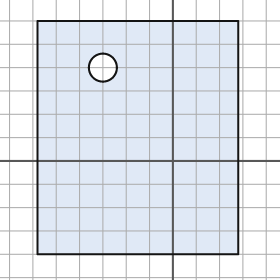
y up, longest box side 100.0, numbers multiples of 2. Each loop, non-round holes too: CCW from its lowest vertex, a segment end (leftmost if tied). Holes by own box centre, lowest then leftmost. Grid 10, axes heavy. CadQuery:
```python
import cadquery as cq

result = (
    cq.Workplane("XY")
    .moveTo(-58.0, -40.0)
    .lineTo(28.0, -40.0)
    .lineTo(28.0, 60.0)
    .lineTo(-58.0, 60.0)
    .close()
    .moveTo(-30.0, 40.0)
    .circle(6.0)
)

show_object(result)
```